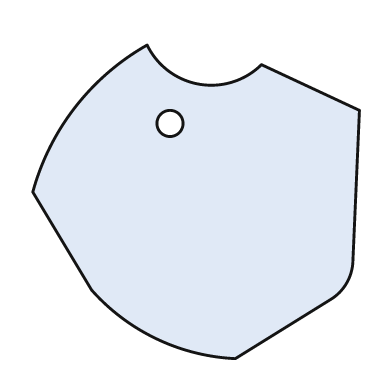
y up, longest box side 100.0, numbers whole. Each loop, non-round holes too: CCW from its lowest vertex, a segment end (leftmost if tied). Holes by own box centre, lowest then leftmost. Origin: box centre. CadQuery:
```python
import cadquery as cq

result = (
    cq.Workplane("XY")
    .moveTo(12.0, -48.0)
    .lineTo(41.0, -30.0)
    .threePointArc((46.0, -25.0), (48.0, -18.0))
    .lineTo(50.0, 28.0)
    .lineTo(20.0, 42.0)
    .threePointArc((1.0, 36.0), (-15.0, 48.0))
    .threePointArc((-37.0, 29.0), (-50.0, 3.0))
    .lineTo(-32.0, -27.0)
    .threePointArc((-12.0, -42.0), (12.0, -48.0))
    .close()
    .moveTo(-8.0, 24.0)
    .circle(4.0)
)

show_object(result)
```